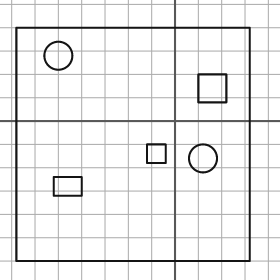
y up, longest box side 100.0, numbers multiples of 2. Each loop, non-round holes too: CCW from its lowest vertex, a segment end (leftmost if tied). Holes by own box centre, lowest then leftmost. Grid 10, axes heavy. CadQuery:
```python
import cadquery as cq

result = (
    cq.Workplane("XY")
    .moveTo(-68.0, -60.0)
    .lineTo(32.0, -60.0)
    .lineTo(32.0, 40.0)
    .lineTo(-68.0, 40.0)
    .close()
    .moveTo(-52.0, -32.0)
    .lineTo(-40.0, -32.0)
    .lineTo(-40.0, -24.0)
    .lineTo(-52.0, -24.0)
    .close()
    .moveTo(12.0, -16.0)
    .circle(6.0)
    .moveTo(-12.0, -18.0)
    .lineTo(-4.0, -18.0)
    .lineTo(-4.0, -10.0)
    .lineTo(-12.0, -10.0)
    .close()
    .moveTo(10.0, 8.0)
    .lineTo(22.0, 8.0)
    .lineTo(22.0, 20.0)
    .lineTo(10.0, 20.0)
    .close()
    .moveTo(-50.0, 28.0)
    .circle(6.0)
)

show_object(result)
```